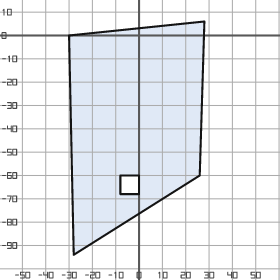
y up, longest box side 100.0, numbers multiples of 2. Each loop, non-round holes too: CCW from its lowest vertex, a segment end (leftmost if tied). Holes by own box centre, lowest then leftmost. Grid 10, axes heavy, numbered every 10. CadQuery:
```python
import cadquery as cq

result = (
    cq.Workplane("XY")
    .moveTo(-28.0, -94.0)
    .lineTo(26.0, -60.0)
    .lineTo(28.0, 6.0)
    .lineTo(-30.0, 0.0)
    .close()
    .moveTo(-8.0, -68.0)
    .lineTo(0.0, -68.0)
    .lineTo(0.0, -60.0)
    .lineTo(-8.0, -60.0)
    .close()
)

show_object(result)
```